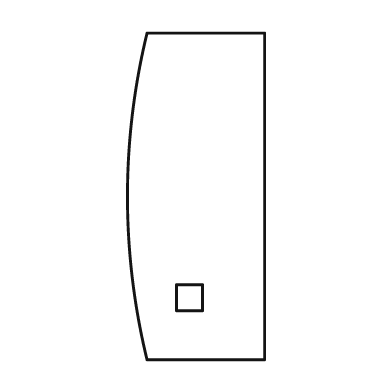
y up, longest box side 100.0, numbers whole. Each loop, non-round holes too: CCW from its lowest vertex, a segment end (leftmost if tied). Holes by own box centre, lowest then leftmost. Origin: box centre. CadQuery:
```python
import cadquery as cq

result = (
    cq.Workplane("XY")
    .moveTo(-15.0, -50.0)
    .lineTo(21.0, -50.0)
    .lineTo(21.0, 50.0)
    .lineTo(-15.0, 50.0)
    .threePointArc((-21.0, 0.0), (-15.0, -50.0))
    .close()
    .moveTo(-6.0, -35.0)
    .lineTo(2.0, -35.0)
    .lineTo(2.0, -27.0)
    .lineTo(-6.0, -27.0)
    .close()
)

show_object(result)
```